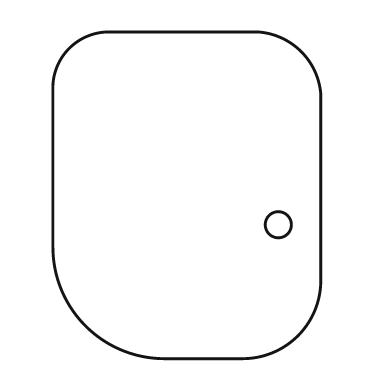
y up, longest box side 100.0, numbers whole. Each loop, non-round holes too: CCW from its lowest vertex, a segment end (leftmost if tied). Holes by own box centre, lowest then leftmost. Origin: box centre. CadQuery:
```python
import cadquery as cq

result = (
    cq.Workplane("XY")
    .moveTo(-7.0, -50.0)
    .lineTo(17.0, -50.0)
    .threePointArc((34.0, -43.0), (41.0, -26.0))
    .lineTo(41.0, 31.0)
    .threePointArc((35.0, 44.0), (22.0, 50.0))
    .lineTo(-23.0, 50.0)
    .threePointArc((-36.0, 45.0), (-41.0, 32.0))
    .lineTo(-41.0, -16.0)
    .threePointArc((-31.0, -40.0), (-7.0, -50.0))
    .close()
    .moveTo(28.0, -9.0)
    .circle(4.0)
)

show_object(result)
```